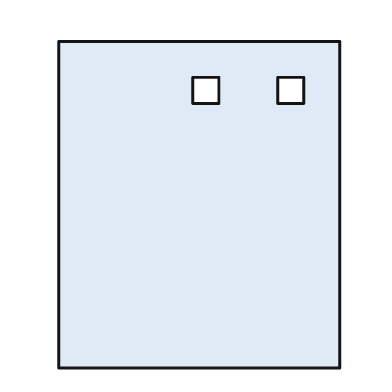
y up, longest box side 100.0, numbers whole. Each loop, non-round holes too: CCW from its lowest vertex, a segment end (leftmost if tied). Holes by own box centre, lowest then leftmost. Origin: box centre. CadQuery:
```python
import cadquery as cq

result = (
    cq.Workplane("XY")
    .moveTo(-43.0, -50.0)
    .lineTo(43.0, -50.0)
    .lineTo(43.0, 50.0)
    .lineTo(-43.0, 50.0)
    .close()
    .moveTo(-2.0, 31.0)
    .lineTo(6.0, 31.0)
    .lineTo(6.0, 39.0)
    .lineTo(-2.0, 39.0)
    .close()
    .moveTo(24.0, 31.0)
    .lineTo(32.0, 31.0)
    .lineTo(32.0, 39.0)
    .lineTo(24.0, 39.0)
    .close()
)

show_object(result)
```